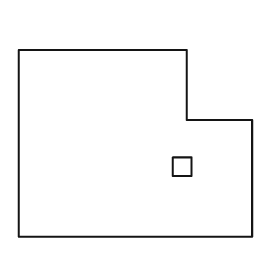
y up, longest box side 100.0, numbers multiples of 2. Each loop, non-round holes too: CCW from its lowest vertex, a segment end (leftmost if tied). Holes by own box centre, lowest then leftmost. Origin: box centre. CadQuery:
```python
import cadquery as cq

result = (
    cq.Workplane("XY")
    .moveTo(-50.0, -40.0)
    .lineTo(50.0, -40.0)
    .lineTo(50.0, 10.0)
    .lineTo(22.0, 10.0)
    .lineTo(22.0, 40.0)
    .lineTo(-50.0, 40.0)
    .close()
    .moveTo(16.0, -14.0)
    .lineTo(24.0, -14.0)
    .lineTo(24.0, -6.0)
    .lineTo(16.0, -6.0)
    .close()
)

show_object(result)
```